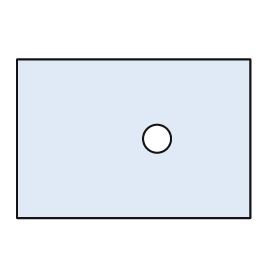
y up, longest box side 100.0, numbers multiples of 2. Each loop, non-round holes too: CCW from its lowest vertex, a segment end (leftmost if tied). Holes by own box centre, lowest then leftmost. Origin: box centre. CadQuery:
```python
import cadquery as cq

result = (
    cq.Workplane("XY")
    .moveTo(-50.0, -34.0)
    .lineTo(50.0, -34.0)
    .lineTo(50.0, 34.0)
    .lineTo(-50.0, 34.0)
    .close()
    .moveTo(10.0, 0.0)
    .circle(6.0)
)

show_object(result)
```